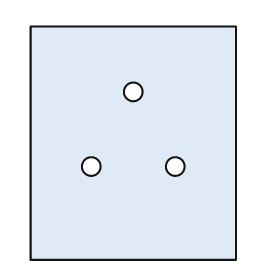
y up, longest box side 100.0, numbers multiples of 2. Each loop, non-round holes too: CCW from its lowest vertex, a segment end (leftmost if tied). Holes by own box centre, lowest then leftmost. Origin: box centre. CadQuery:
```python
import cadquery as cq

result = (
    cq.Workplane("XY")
    .moveTo(-44.0, -50.0)
    .lineTo(44.0, -50.0)
    .lineTo(44.0, 50.0)
    .lineTo(-44.0, 50.0)
    .close()
    .moveTo(-18.0, -10.0)
    .circle(4.0)
    .moveTo(18.0, -10.0)
    .circle(4.0)
    .moveTo(0.0, 22.0)
    .circle(4.0)
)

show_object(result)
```